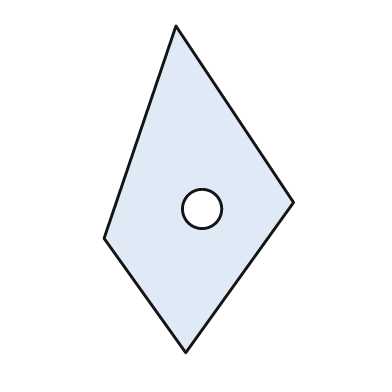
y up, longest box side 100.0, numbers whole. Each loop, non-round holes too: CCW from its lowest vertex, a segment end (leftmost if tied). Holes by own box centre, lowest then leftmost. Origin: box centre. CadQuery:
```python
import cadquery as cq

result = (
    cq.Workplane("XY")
    .moveTo(-4.0, -50.0)
    .lineTo(29.0, -4.0)
    .lineTo(-7.0, 50.0)
    .lineTo(-29.0, -15.0)
    .close()
    .moveTo(1.0, -6.0)
    .circle(6.0)
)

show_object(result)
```